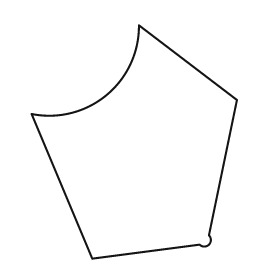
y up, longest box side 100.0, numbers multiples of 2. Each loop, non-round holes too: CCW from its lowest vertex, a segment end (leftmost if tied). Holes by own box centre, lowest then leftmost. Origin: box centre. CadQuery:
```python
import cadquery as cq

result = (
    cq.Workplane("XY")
    .moveTo(-18.0, -50.0)
    .lineTo(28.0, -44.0)
    .threePointArc((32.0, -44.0), (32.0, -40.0))
    .lineTo(44.0, 18.0)
    .lineTo(2.0, 50.0)
    .threePointArc((-12.0, 20.0), (-44.0, 12.0))
    .close()
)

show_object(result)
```